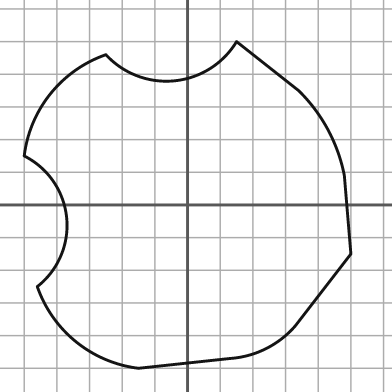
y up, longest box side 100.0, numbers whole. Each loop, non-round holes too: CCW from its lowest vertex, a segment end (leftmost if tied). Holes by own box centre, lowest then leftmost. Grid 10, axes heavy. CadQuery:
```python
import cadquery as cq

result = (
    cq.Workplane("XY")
    .moveTo(-15.0, -50.0)
    .lineTo(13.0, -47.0)
    .threePointArc((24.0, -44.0), (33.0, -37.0))
    .lineTo(50.0, -15.0)
    .lineTo(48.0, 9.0)
    .threePointArc((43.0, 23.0), (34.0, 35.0))
    .lineTo(15.0, 50.0)
    .threePointArc((-4.0, 38.0), (-25.0, 46.0))
    .threePointArc((-42.0, 34.0), (-50.0, 15.0))
    .threePointArc((-37.0, -4.0), (-46.0, -25.0))
    .threePointArc((-34.0, -42.0), (-15.0, -50.0))
    .close()
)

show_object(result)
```